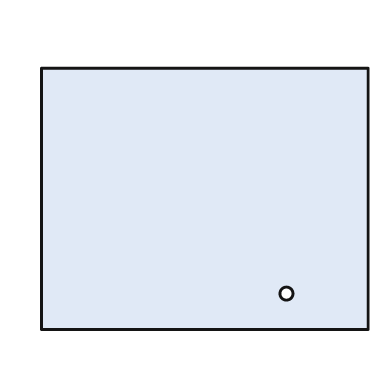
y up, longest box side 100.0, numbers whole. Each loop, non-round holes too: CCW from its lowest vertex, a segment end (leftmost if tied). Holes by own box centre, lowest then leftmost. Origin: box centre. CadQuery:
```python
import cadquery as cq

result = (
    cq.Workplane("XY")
    .moveTo(-50.0, -40.0)
    .lineTo(50.0, -40.0)
    .lineTo(50.0, 40.0)
    .lineTo(-50.0, 40.0)
    .close()
    .moveTo(25.0, -29.0)
    .circle(2.0)
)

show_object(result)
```